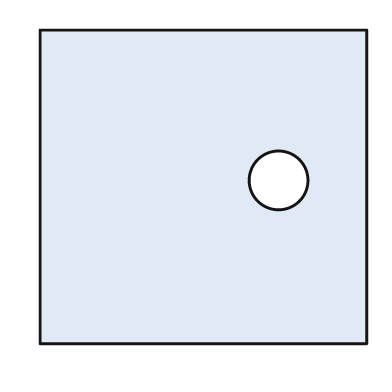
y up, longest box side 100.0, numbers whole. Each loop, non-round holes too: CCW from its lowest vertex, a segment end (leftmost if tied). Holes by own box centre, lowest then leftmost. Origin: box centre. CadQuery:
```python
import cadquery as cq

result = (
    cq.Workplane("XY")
    .moveTo(-50.0, -48.0)
    .lineTo(50.0, -48.0)
    .lineTo(50.0, 48.0)
    .lineTo(-50.0, 48.0)
    .close()
    .moveTo(23.0, 2.0)
    .circle(9.0)
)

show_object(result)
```